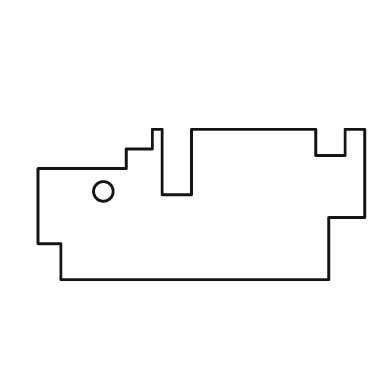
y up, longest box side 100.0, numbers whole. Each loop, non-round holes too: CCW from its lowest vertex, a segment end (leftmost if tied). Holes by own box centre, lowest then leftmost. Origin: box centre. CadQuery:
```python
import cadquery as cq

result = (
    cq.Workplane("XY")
    .moveTo(-43.0, -23.0)
    .lineTo(39.0, -23.0)
    .lineTo(39.0, -4.0)
    .lineTo(50.0, -4.0)
    .lineTo(50.0, 23.0)
    .lineTo(44.0, 23.0)
    .lineTo(44.0, 15.0)
    .lineTo(35.0, 15.0)
    .lineTo(35.0, 23.0)
    .lineTo(-3.0, 23.0)
    .lineTo(-3.0, 3.0)
    .lineTo(-12.0, 3.0)
    .lineTo(-12.0, 23.0)
    .lineTo(-15.0, 23.0)
    .lineTo(-15.0, 17.0)
    .lineTo(-23.0, 17.0)
    .lineTo(-23.0, 11.0)
    .lineTo(-50.0, 11.0)
    .lineTo(-50.0, -12.0)
    .lineTo(-43.0, -12.0)
    .close()
    .moveTo(-30.0, 4.0)
    .circle(3.0)
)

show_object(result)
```